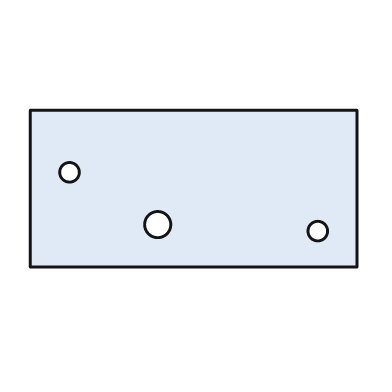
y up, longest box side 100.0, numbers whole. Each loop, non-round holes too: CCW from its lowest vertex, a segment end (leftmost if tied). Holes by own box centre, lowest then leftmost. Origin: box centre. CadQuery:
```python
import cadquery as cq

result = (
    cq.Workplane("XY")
    .moveTo(-50.0, -24.0)
    .lineTo(50.0, -24.0)
    .lineTo(50.0, 24.0)
    .lineTo(-50.0, 24.0)
    .close()
    .moveTo(38.0, -13.0)
    .circle(3.0)
    .moveTo(-11.0, -11.0)
    .circle(4.0)
    .moveTo(-38.0, 5.0)
    .circle(3.0)
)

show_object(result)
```